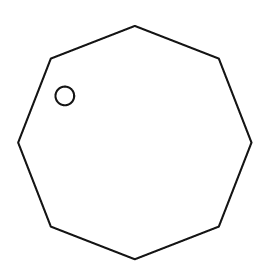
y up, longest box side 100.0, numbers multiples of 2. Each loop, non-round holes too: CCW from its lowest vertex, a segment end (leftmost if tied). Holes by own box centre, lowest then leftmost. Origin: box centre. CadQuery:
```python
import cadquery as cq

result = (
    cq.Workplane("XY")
    .moveTo(0.0, -50.0)
    .lineTo(36.0, -36.0)
    .lineTo(50.0, 0.0)
    .lineTo(36.0, 36.0)
    .lineTo(0.0, 50.0)
    .lineTo(-36.0, 36.0)
    .lineTo(-50.0, 0.0)
    .lineTo(-36.0, -36.0)
    .close()
    .moveTo(-30.0, 20.0)
    .circle(4.0)
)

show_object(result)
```